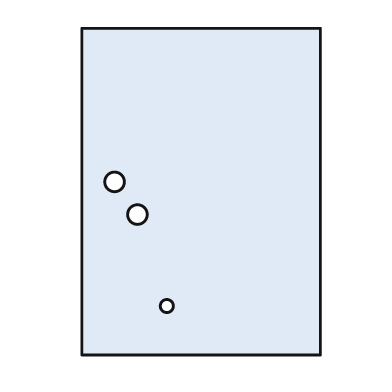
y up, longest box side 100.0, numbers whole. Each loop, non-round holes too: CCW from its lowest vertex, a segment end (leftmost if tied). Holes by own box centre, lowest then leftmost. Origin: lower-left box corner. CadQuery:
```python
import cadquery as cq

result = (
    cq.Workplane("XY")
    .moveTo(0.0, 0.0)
    .lineTo(73.0, 0.0)
    .lineTo(73.0, 100.0)
    .lineTo(0.0, 100.0)
    .close()
    .moveTo(26.0, 15.0)
    .circle(2.0)
    .moveTo(17.0, 43.0)
    .circle(3.0)
    .moveTo(10.0, 53.0)
    .circle(3.0)
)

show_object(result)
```